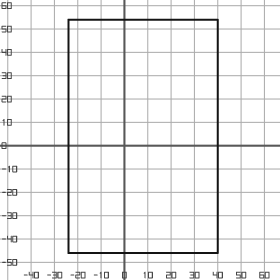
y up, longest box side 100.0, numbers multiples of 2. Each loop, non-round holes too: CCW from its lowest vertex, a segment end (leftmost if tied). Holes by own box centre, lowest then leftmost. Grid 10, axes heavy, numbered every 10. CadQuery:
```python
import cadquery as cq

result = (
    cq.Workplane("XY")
    .moveTo(-24.0, -46.0)
    .lineTo(40.0, -46.0)
    .lineTo(40.0, 54.0)
    .lineTo(-24.0, 54.0)
    .close()
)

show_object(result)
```